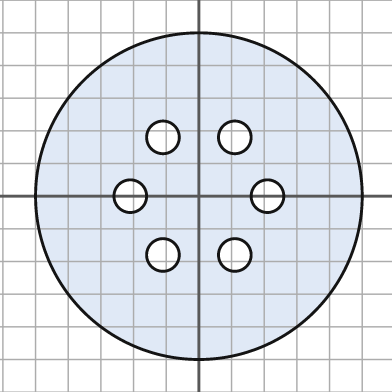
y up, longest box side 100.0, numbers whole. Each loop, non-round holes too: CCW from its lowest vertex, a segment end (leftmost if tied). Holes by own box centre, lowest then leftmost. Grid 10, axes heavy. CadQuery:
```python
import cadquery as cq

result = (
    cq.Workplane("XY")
    .moveTo(0.0, 0.0)
    .circle(50.0)
    .moveTo(-11.0, -18.0)
    .circle(5.0)
    .moveTo(11.0, -18.0)
    .circle(5.0)
    .moveTo(-21.0, 0.0)
    .circle(5.0)
    .moveTo(21.0, 0.0)
    .circle(5.0)
    .moveTo(-11.0, 18.0)
    .circle(5.0)
    .moveTo(11.0, 18.0)
    .circle(5.0)
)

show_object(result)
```